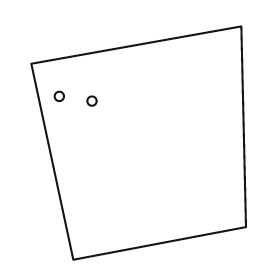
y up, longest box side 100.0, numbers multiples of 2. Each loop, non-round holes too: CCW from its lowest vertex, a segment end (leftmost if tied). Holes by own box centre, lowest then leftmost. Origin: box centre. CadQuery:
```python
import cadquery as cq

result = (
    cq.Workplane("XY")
    .moveTo(-28.0, -50.0)
    .lineTo(46.0, -36.0)
    .lineTo(44.0, 50.0)
    .lineTo(-46.0, 34.0)
    .close()
    .moveTo(-20.0, 18.0)
    .circle(2.0)
    .moveTo(-34.0, 20.0)
    .circle(2.0)
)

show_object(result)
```